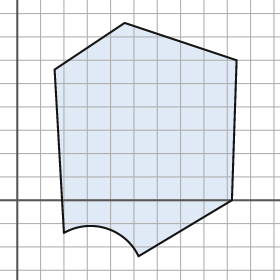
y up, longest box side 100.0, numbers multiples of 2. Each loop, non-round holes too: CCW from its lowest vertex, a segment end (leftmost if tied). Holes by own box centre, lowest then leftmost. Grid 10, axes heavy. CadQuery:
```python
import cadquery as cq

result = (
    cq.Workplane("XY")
    .moveTo(52.0, -24.0)
    .lineTo(92.0, 0.0)
    .lineTo(94.0, 60.0)
    .lineTo(46.0, 76.0)
    .lineTo(16.0, 56.0)
    .lineTo(20.0, -14.0)
    .threePointArc((38.0, -12.0), (52.0, -24.0))
    .close()
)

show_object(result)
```